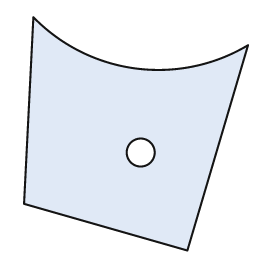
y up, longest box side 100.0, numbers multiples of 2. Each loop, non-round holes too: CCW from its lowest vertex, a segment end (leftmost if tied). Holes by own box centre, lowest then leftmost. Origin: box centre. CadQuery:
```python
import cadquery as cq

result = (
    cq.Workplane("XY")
    .moveTo(22.0, -50.0)
    .lineTo(48.0, 38.0)
    .threePointArc((0.0, 28.0), (-44.0, 50.0))
    .lineTo(-48.0, -30.0)
    .close()
    .moveTo(2.0, -8.0)
    .circle(6.0)
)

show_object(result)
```